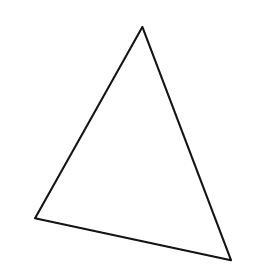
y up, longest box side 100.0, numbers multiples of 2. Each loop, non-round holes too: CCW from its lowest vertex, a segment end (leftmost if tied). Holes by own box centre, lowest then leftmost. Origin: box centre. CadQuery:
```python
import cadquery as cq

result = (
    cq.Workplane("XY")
    .moveTo(42.0, -50.0)
    .lineTo(4.0, 50.0)
    .lineTo(-42.0, -32.0)
    .close()
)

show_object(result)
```